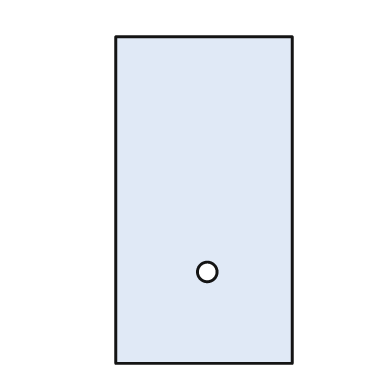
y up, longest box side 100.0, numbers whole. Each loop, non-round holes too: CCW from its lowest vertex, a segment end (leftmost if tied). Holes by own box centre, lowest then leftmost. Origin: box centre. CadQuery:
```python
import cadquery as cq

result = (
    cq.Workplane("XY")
    .moveTo(-27.0, -50.0)
    .lineTo(27.0, -50.0)
    .lineTo(27.0, 50.0)
    .lineTo(-27.0, 50.0)
    .close()
    .moveTo(1.0, -22.0)
    .circle(3.0)
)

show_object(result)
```